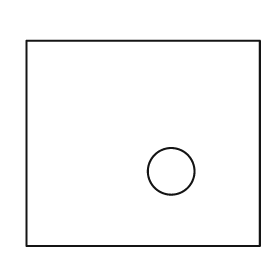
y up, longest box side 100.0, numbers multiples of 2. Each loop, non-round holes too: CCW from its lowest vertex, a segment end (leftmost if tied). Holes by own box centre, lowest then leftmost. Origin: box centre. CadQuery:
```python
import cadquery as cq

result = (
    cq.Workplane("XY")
    .moveTo(-50.0, -44.0)
    .lineTo(50.0, -44.0)
    .lineTo(50.0, 44.0)
    .lineTo(-50.0, 44.0)
    .close()
    .moveTo(12.0, -12.0)
    .circle(10.0)
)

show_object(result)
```